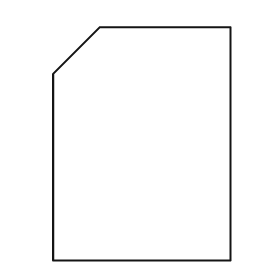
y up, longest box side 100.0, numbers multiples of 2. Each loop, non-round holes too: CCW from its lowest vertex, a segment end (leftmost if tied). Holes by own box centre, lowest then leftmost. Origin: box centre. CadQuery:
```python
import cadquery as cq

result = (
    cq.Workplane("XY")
    .moveTo(-38.0, -50.0)
    .lineTo(38.0, -50.0)
    .lineTo(38.0, 50.0)
    .lineTo(-18.0, 50.0)
    .lineTo(-38.0, 30.0)
    .close()
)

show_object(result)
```